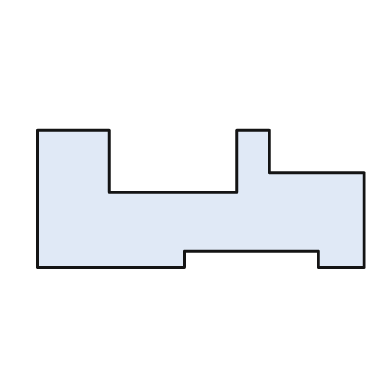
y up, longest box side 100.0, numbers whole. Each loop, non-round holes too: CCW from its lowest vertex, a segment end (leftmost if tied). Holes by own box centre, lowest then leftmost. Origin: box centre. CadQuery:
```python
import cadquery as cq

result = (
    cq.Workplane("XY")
    .moveTo(-50.0, -21.0)
    .lineTo(-5.0, -21.0)
    .lineTo(-5.0, -16.0)
    .lineTo(36.0, -16.0)
    .lineTo(36.0, -21.0)
    .lineTo(50.0, -21.0)
    .lineTo(50.0, 8.0)
    .lineTo(21.0, 8.0)
    .lineTo(21.0, 21.0)
    .lineTo(11.0, 21.0)
    .lineTo(11.0, 2.0)
    .lineTo(-28.0, 2.0)
    .lineTo(-28.0, 21.0)
    .lineTo(-50.0, 21.0)
    .close()
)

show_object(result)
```